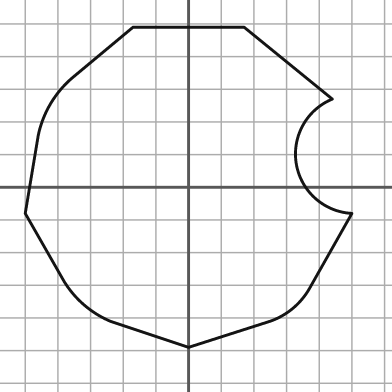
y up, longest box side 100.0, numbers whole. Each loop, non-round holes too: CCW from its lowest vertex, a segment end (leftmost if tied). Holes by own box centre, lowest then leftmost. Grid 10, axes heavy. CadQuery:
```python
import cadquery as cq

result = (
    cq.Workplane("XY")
    .moveTo(0.0, -49.0)
    .lineTo(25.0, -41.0)
    .threePointArc((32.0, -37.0), (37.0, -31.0))
    .lineTo(50.0, -8.0)
    .threePointArc((33.0, 7.0), (44.0, 27.0))
    .lineTo(17.0, 49.0)
    .lineTo(-17.0, 49.0)
    .lineTo(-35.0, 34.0)
    .threePointArc((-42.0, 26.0), (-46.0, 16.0))
    .lineTo(-50.0, -8.0)
    .lineTo(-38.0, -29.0)
    .threePointArc((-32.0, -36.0), (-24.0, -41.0))
    .close()
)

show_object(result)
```